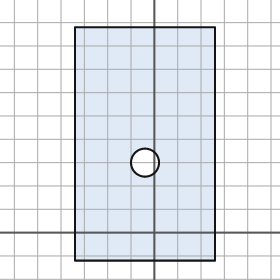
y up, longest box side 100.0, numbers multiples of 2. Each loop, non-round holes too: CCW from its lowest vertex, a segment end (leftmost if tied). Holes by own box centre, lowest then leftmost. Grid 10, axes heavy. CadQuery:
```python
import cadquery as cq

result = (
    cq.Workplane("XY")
    .moveTo(-34.0, -12.0)
    .lineTo(26.0, -12.0)
    .lineTo(26.0, 88.0)
    .lineTo(-34.0, 88.0)
    .close()
    .moveTo(-4.0, 30.0)
    .circle(6.0)
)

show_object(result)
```